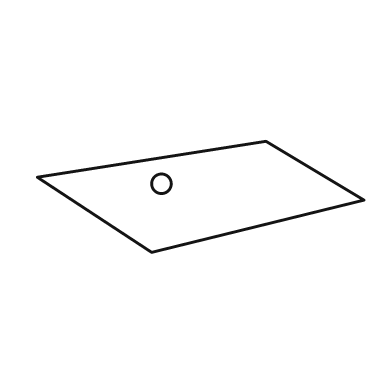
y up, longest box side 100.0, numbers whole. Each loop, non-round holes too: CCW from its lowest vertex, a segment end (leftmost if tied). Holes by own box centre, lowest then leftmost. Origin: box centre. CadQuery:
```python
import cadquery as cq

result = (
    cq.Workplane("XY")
    .moveTo(-15.0, -17.0)
    .lineTo(50.0, -1.0)
    .lineTo(20.0, 17.0)
    .lineTo(-50.0, 6.0)
    .close()
    .moveTo(-12.0, 4.0)
    .circle(3.0)
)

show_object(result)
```